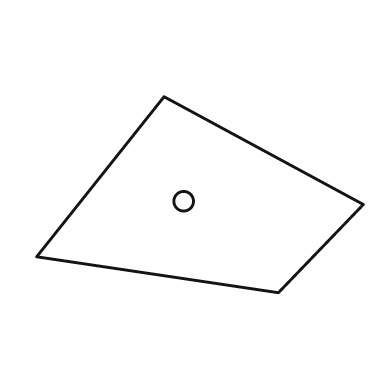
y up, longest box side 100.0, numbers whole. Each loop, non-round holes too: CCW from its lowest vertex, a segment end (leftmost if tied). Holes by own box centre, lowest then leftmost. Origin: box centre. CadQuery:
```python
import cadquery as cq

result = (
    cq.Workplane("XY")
    .moveTo(24.0, -30.0)
    .lineTo(50.0, -3.0)
    .lineTo(-11.0, 30.0)
    .lineTo(-50.0, -19.0)
    .close()
    .moveTo(-5.0, -2.0)
    .circle(3.0)
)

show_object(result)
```